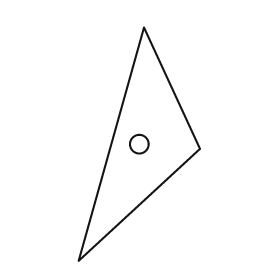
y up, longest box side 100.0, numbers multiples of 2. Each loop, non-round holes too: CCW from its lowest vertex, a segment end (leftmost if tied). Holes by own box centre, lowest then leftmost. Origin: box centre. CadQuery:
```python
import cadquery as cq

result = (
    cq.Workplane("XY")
    .moveTo(-26.0, -50.0)
    .lineTo(26.0, -2.0)
    .lineTo(2.0, 50.0)
    .close()
    .moveTo(0.0, 0.0)
    .circle(4.0)
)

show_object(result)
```